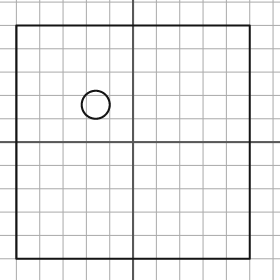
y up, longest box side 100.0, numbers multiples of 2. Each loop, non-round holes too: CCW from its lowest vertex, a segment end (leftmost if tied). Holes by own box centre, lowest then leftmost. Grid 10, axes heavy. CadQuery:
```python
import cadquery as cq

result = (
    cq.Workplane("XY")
    .moveTo(-50.0, -50.0)
    .lineTo(50.0, -50.0)
    .lineTo(50.0, 50.0)
    .lineTo(-50.0, 50.0)
    .close()
    .moveTo(-16.0, 16.0)
    .circle(6.0)
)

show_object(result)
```